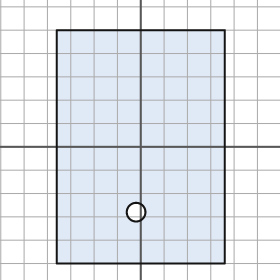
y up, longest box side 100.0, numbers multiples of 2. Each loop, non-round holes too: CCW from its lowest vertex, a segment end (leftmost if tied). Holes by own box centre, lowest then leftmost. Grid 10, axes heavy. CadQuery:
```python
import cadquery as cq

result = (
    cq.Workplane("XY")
    .moveTo(-36.0, -50.0)
    .lineTo(36.0, -50.0)
    .lineTo(36.0, 50.0)
    .lineTo(-36.0, 50.0)
    .close()
    .moveTo(-2.0, -28.0)
    .circle(4.0)
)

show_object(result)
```